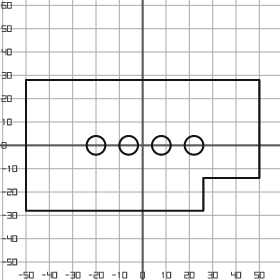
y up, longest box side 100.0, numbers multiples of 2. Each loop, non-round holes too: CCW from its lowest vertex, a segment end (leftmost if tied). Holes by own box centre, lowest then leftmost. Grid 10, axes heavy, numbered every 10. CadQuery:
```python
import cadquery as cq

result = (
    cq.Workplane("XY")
    .moveTo(-50.0, -28.0)
    .lineTo(26.0, -28.0)
    .lineTo(26.0, -14.0)
    .lineTo(50.0, -14.0)
    .lineTo(50.0, 28.0)
    .lineTo(-50.0, 28.0)
    .close()
    .moveTo(-20.0, 0.0)
    .circle(4.0)
    .moveTo(-6.0, 0.0)
    .circle(4.0)
    .moveTo(8.0, 0.0)
    .circle(4.0)
    .moveTo(22.0, 0.0)
    .circle(4.0)
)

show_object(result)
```